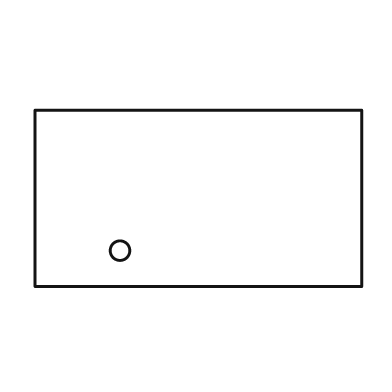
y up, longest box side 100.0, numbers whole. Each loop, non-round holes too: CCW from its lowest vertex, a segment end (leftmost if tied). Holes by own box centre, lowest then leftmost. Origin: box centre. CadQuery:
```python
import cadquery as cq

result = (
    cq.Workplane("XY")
    .moveTo(-50.0, -27.0)
    .lineTo(50.0, -27.0)
    .lineTo(50.0, 27.0)
    .lineTo(-50.0, 27.0)
    .close()
    .moveTo(-24.0, -16.0)
    .circle(3.0)
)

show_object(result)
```